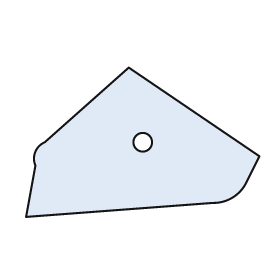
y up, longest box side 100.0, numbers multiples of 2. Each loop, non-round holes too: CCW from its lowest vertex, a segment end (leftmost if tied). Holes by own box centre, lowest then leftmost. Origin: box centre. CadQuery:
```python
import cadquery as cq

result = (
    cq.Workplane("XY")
    .moveTo(-50.0, -32.0)
    .lineTo(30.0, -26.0)
    .threePointArc((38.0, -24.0), (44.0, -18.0))
    .lineTo(50.0, -6.0)
    .lineTo(-6.0, 32.0)
    .lineTo(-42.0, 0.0)
    .threePointArc((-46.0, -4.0), (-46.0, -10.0))
    .close()
    .moveTo(0.0, 0.0)
    .circle(4.0)
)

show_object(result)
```